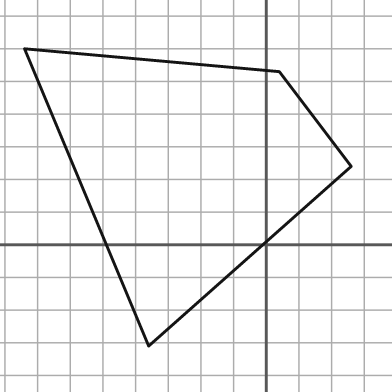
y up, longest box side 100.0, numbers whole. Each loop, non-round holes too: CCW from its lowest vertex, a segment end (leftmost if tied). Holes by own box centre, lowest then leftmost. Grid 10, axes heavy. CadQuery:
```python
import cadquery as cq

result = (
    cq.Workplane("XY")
    .moveTo(-36.0, -31.0)
    .lineTo(26.0, 24.0)
    .lineTo(4.0, 53.0)
    .lineTo(-74.0, 60.0)
    .close()
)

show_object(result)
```